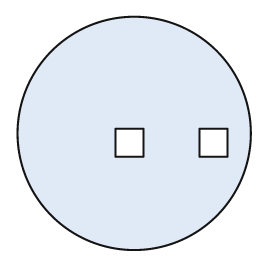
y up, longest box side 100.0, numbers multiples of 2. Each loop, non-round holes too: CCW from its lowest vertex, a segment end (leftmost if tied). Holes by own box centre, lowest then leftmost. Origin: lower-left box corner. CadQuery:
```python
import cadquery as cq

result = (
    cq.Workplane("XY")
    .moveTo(50.0, 50.0)
    .circle(50.0)
    .moveTo(42.0, 40.0)
    .lineTo(54.0, 40.0)
    .lineTo(54.0, 52.0)
    .lineTo(42.0, 52.0)
    .close()
    .moveTo(78.0, 40.0)
    .lineTo(90.0, 40.0)
    .lineTo(90.0, 52.0)
    .lineTo(78.0, 52.0)
    .close()
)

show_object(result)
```